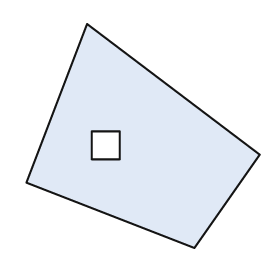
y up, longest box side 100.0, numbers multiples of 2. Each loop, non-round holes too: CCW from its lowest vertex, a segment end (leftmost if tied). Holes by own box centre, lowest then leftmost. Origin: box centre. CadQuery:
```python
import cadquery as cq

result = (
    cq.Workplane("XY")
    .moveTo(22.0, -48.0)
    .lineTo(50.0, -8.0)
    .lineTo(-24.0, 48.0)
    .lineTo(-50.0, -20.0)
    .close()
    .moveTo(-22.0, -10.0)
    .lineTo(-10.0, -10.0)
    .lineTo(-10.0, 2.0)
    .lineTo(-22.0, 2.0)
    .close()
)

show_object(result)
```